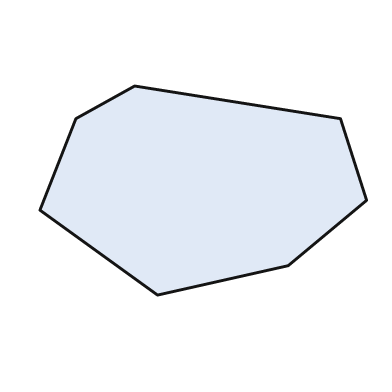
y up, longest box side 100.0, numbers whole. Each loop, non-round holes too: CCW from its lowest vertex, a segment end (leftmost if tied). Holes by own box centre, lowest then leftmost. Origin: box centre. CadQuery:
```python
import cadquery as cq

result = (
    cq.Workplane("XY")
    .moveTo(-14.0, -32.0)
    .lineTo(26.0, -23.0)
    .lineTo(50.0, -3.0)
    .lineTo(42.0, 22.0)
    .lineTo(-21.0, 32.0)
    .lineTo(-39.0, 22.0)
    .lineTo(-50.0, -6.0)
    .close()
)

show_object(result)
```